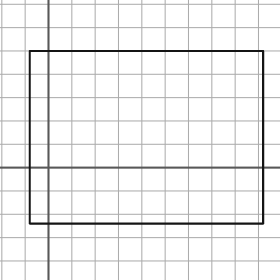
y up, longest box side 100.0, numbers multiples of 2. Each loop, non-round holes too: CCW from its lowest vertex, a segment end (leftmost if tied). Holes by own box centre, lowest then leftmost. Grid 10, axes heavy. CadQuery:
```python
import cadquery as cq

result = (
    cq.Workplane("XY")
    .moveTo(-8.0, -24.0)
    .lineTo(92.0, -24.0)
    .lineTo(92.0, 50.0)
    .lineTo(-8.0, 50.0)
    .close()
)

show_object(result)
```